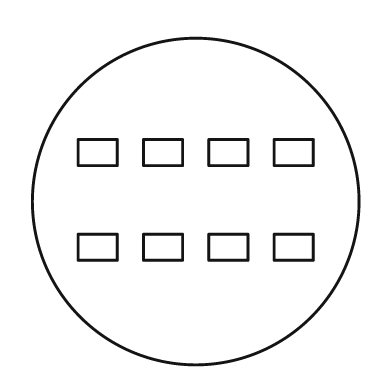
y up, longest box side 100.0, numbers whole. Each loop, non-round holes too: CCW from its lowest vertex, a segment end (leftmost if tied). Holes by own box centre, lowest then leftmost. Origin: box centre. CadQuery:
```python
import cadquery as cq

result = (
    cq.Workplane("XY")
    .moveTo(0.0, 0.0)
    .circle(50.0)
    .moveTo(-36.0, -18.0)
    .lineTo(-24.0, -18.0)
    .lineTo(-24.0, -10.0)
    .lineTo(-36.0, -10.0)
    .close()
    .moveTo(-16.0, -18.0)
    .lineTo(-4.0, -18.0)
    .lineTo(-4.0, -10.0)
    .lineTo(-16.0, -10.0)
    .close()
    .moveTo(4.0, -18.0)
    .lineTo(16.0, -18.0)
    .lineTo(16.0, -10.0)
    .lineTo(4.0, -10.0)
    .close()
    .moveTo(24.0, -18.0)
    .lineTo(36.0, -18.0)
    .lineTo(36.0, -10.0)
    .lineTo(24.0, -10.0)
    .close()
    .moveTo(-36.0, 11.0)
    .lineTo(-24.0, 11.0)
    .lineTo(-24.0, 19.0)
    .lineTo(-36.0, 19.0)
    .close()
    .moveTo(-16.0, 11.0)
    .lineTo(-4.0, 11.0)
    .lineTo(-4.0, 19.0)
    .lineTo(-16.0, 19.0)
    .close()
    .moveTo(4.0, 11.0)
    .lineTo(16.0, 11.0)
    .lineTo(16.0, 19.0)
    .lineTo(4.0, 19.0)
    .close()
    .moveTo(24.0, 11.0)
    .lineTo(36.0, 11.0)
    .lineTo(36.0, 19.0)
    .lineTo(24.0, 19.0)
    .close()
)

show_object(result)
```